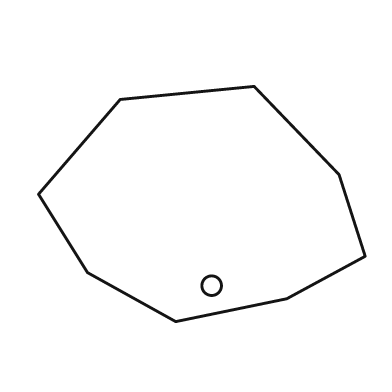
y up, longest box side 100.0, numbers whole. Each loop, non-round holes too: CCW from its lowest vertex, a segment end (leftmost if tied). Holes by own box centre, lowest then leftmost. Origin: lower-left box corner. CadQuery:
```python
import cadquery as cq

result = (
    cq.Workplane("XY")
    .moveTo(42.0, 0.0)
    .lineTo(76.0, 7.0)
    .lineTo(100.0, 20.0)
    .lineTo(92.0, 45.0)
    .lineTo(66.0, 72.0)
    .lineTo(25.0, 68.0)
    .lineTo(0.0, 39.0)
    .lineTo(15.0, 15.0)
    .close()
    .moveTo(53.0, 11.0)
    .circle(3.0)
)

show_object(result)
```